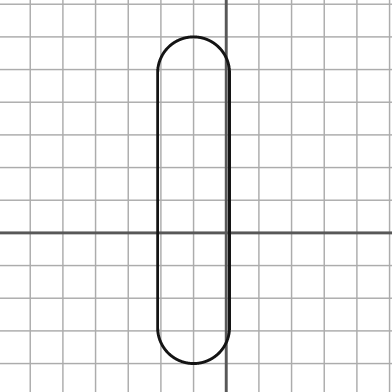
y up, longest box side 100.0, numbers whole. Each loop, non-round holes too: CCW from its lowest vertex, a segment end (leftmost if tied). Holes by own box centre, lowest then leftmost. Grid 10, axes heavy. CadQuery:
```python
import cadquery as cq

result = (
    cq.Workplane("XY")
    .moveTo(-21.0, -29.0)
    .threePointArc((-10.0, -40.0), (1.0, -29.0))
    .lineTo(1.0, 49.0)
    .threePointArc((-10.0, 60.0), (-21.0, 49.0))
    .close()
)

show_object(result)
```